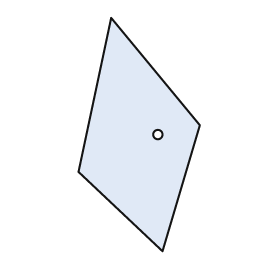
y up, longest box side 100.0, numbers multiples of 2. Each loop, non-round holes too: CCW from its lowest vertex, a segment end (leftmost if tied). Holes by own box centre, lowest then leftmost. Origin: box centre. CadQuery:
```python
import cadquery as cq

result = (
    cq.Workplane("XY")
    .moveTo(10.0, -50.0)
    .lineTo(26.0, 4.0)
    .lineTo(-12.0, 50.0)
    .lineTo(-26.0, -16.0)
    .close()
    .moveTo(8.0, 0.0)
    .circle(2.0)
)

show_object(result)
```